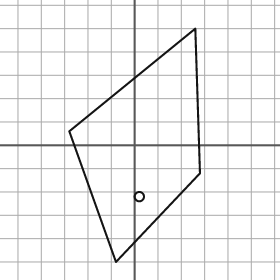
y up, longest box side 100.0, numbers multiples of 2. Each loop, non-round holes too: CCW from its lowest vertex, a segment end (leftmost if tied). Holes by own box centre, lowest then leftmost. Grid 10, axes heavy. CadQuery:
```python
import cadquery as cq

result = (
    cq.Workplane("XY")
    .moveTo(-8.0, -50.0)
    .lineTo(28.0, -12.0)
    .lineTo(26.0, 50.0)
    .lineTo(-28.0, 6.0)
    .close()
    .moveTo(2.0, -22.0)
    .circle(2.0)
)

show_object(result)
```